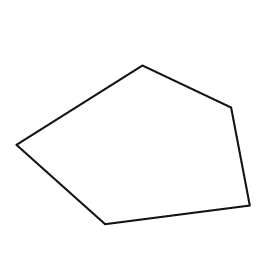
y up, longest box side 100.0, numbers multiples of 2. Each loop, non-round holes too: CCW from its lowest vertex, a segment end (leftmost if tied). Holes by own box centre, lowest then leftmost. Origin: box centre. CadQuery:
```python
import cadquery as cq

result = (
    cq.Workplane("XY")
    .moveTo(-12.0, -34.0)
    .lineTo(50.0, -26.0)
    .lineTo(42.0, 16.0)
    .lineTo(4.0, 34.0)
    .lineTo(-50.0, 0.0)
    .close()
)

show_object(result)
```